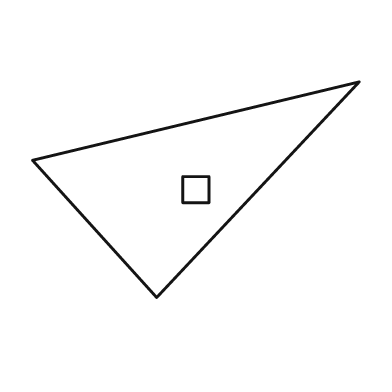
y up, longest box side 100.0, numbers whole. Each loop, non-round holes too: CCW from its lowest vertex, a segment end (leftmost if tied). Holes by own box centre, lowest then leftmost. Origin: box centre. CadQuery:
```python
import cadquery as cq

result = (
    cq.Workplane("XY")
    .moveTo(-12.0, -33.0)
    .lineTo(50.0, 33.0)
    .lineTo(-50.0, 9.0)
    .close()
    .moveTo(-4.0, -4.0)
    .lineTo(4.0, -4.0)
    .lineTo(4.0, 4.0)
    .lineTo(-4.0, 4.0)
    .close()
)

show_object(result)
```